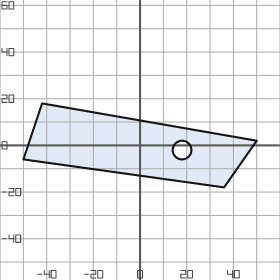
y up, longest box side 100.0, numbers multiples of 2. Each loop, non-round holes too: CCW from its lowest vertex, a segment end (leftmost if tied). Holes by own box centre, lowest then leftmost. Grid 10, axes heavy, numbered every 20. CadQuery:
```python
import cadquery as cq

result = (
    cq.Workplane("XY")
    .moveTo(36.0, -18.0)
    .lineTo(50.0, 2.0)
    .lineTo(-42.0, 18.0)
    .lineTo(-50.0, -6.0)
    .close()
    .moveTo(18.0, -2.0)
    .circle(4.0)
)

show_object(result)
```